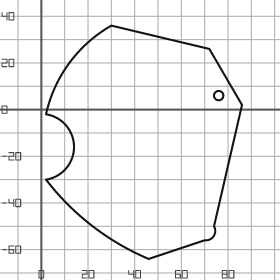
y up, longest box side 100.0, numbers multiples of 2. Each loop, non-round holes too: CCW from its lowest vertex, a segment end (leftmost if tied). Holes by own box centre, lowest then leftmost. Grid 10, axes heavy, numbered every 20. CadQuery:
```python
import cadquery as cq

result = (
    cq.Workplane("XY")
    .moveTo(46.0, -64.0)
    .lineTo(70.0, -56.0)
    .threePointArc((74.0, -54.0), (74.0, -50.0))
    .lineTo(86.0, 2.0)
    .lineTo(72.0, 26.0)
    .lineTo(30.0, 36.0)
    .threePointArc((12.0, 20.0), (2.0, -2.0))
    .threePointArc((14.0, -16.0), (2.0, -30.0))
    .threePointArc((22.0, -50.0), (46.0, -64.0))
    .close()
    .moveTo(76.0, 6.0)
    .circle(2.0)
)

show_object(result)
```